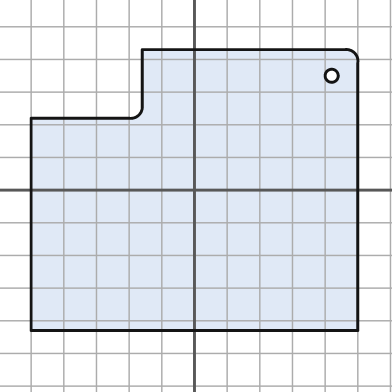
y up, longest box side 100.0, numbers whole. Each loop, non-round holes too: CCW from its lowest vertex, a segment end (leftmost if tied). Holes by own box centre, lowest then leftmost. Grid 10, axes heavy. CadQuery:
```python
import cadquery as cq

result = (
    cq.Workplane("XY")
    .moveTo(-50.0, -43.0)
    .lineTo(50.0, -43.0)
    .lineTo(50.0, 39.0)
    .threePointArc((49.0, 42.0), (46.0, 43.0))
    .lineTo(-16.0, 43.0)
    .lineTo(-16.0, 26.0)
    .threePointArc((-17.0, 23.0), (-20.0, 22.0))
    .lineTo(-50.0, 22.0)
    .close()
    .moveTo(42.0, 35.0)
    .circle(2.0)
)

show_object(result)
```